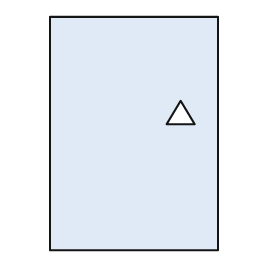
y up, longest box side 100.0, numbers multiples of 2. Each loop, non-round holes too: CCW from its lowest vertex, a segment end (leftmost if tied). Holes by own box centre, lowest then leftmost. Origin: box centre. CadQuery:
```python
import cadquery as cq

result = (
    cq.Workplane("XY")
    .moveTo(-36.0, -50.0)
    .lineTo(36.0, -50.0)
    .lineTo(36.0, 50.0)
    .lineTo(-36.0, 50.0)
    .close()
    .moveTo(14.0, 4.0)
    .lineTo(26.0, 4.0)
    .lineTo(20.0, 14.0)
    .close()
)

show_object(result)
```